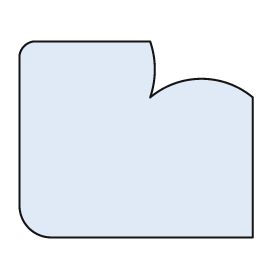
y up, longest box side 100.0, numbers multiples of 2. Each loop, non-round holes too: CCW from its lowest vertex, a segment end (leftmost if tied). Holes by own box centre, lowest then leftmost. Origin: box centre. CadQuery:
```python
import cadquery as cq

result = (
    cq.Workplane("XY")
    .moveTo(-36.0, -42.0)
    .lineTo(50.0, -42.0)
    .lineTo(50.0, 18.0)
    .threePointArc((28.0, 26.0), (6.0, 18.0))
    .threePointArc((8.0, 30.0), (6.0, 42.0))
    .lineTo(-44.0, 42.0)
    .threePointArc((-48.0, 40.0), (-50.0, 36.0))
    .lineTo(-50.0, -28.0)
    .threePointArc((-46.0, -38.0), (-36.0, -42.0))
    .close()
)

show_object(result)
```